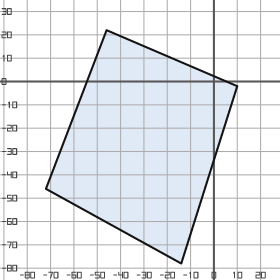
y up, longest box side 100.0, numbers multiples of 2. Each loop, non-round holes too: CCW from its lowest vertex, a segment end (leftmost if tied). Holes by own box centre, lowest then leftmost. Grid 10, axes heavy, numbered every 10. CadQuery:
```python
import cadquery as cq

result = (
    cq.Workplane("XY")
    .moveTo(-14.0, -78.0)
    .lineTo(10.0, -2.0)
    .lineTo(-46.0, 22.0)
    .lineTo(-72.0, -46.0)
    .close()
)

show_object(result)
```